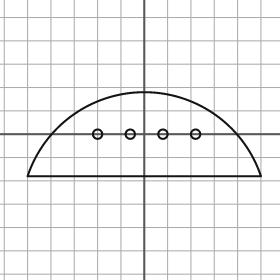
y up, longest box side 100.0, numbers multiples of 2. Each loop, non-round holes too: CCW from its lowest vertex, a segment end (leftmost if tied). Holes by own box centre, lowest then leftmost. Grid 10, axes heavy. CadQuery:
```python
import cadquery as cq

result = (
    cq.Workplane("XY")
    .moveTo(-50.0, -18.0)
    .lineTo(50.0, -18.0)
    .threePointArc((0.0, 18.0), (-50.0, -18.0))
    .close()
    .moveTo(-20.0, 0.0)
    .circle(2.0)
    .moveTo(-6.0, 0.0)
    .circle(2.0)
    .moveTo(8.0, 0.0)
    .circle(2.0)
    .moveTo(22.0, 0.0)
    .circle(2.0)
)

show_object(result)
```